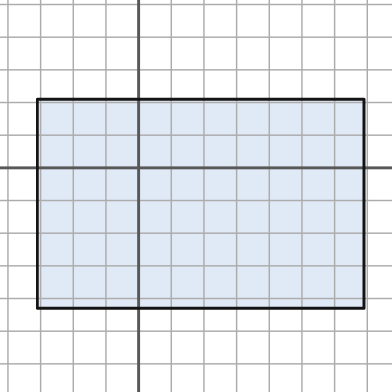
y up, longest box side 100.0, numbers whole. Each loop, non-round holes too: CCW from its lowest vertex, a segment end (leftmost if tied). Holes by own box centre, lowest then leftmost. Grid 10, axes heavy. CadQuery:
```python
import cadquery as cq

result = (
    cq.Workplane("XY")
    .moveTo(-31.0, -43.0)
    .lineTo(69.0, -43.0)
    .lineTo(69.0, 21.0)
    .lineTo(-31.0, 21.0)
    .close()
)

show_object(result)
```